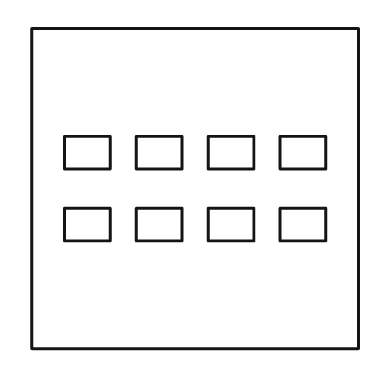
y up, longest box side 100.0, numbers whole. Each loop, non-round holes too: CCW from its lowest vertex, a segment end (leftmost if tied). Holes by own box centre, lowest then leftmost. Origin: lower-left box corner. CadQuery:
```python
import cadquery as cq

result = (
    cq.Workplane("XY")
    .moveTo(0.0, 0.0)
    .lineTo(100.0, 0.0)
    .lineTo(100.0, 98.0)
    .lineTo(0.0, 98.0)
    .close()
    .moveTo(10.0, 33.0)
    .lineTo(24.0, 33.0)
    .lineTo(24.0, 43.0)
    .lineTo(10.0, 43.0)
    .close()
    .moveTo(32.0, 33.0)
    .lineTo(46.0, 33.0)
    .lineTo(46.0, 43.0)
    .lineTo(32.0, 43.0)
    .close()
    .moveTo(54.0, 33.0)
    .lineTo(68.0, 33.0)
    .lineTo(68.0, 43.0)
    .lineTo(54.0, 43.0)
    .close()
    .moveTo(76.0, 33.0)
    .lineTo(90.0, 33.0)
    .lineTo(90.0, 43.0)
    .lineTo(76.0, 43.0)
    .close()
    .moveTo(10.0, 55.0)
    .lineTo(24.0, 55.0)
    .lineTo(24.0, 65.0)
    .lineTo(10.0, 65.0)
    .close()
    .moveTo(32.0, 55.0)
    .lineTo(46.0, 55.0)
    .lineTo(46.0, 65.0)
    .lineTo(32.0, 65.0)
    .close()
    .moveTo(54.0, 55.0)
    .lineTo(68.0, 55.0)
    .lineTo(68.0, 65.0)
    .lineTo(54.0, 65.0)
    .close()
    .moveTo(76.0, 55.0)
    .lineTo(90.0, 55.0)
    .lineTo(90.0, 65.0)
    .lineTo(76.0, 65.0)
    .close()
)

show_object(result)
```